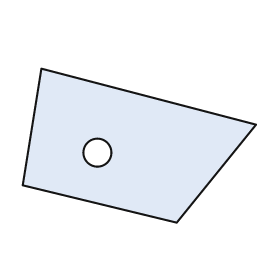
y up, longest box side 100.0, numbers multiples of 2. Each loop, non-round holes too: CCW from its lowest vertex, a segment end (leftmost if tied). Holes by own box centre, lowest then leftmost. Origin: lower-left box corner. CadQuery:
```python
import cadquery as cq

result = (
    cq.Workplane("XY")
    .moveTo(66.0, 0.0)
    .lineTo(100.0, 42.0)
    .lineTo(8.0, 66.0)
    .lineTo(0.0, 16.0)
    .close()
    .moveTo(32.0, 30.0)
    .circle(6.0)
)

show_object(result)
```